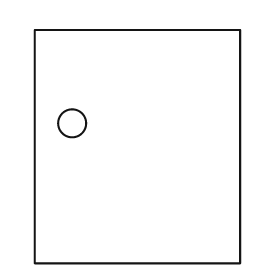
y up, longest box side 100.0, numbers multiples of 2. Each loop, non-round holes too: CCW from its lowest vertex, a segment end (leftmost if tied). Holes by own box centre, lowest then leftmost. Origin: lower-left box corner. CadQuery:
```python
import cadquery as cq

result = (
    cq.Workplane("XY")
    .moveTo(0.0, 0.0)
    .lineTo(88.0, 0.0)
    .lineTo(88.0, 100.0)
    .lineTo(0.0, 100.0)
    .close()
    .moveTo(16.0, 60.0)
    .circle(6.0)
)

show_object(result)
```